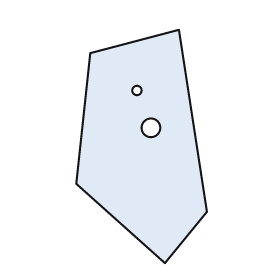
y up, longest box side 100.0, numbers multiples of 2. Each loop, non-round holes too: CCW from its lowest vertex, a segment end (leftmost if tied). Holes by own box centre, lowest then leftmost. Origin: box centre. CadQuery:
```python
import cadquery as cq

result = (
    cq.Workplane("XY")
    .moveTo(10.0, -50.0)
    .lineTo(28.0, -28.0)
    .lineTo(16.0, 50.0)
    .lineTo(-22.0, 40.0)
    .lineTo(-28.0, -16.0)
    .close()
    .moveTo(4.0, 8.0)
    .circle(4.0)
    .moveTo(-2.0, 24.0)
    .circle(2.0)
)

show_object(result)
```